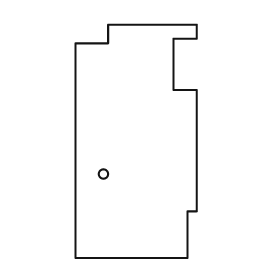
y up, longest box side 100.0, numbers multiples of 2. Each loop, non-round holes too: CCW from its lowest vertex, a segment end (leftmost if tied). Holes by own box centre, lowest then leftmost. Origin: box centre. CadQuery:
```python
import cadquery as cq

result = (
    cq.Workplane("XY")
    .moveTo(-26.0, -50.0)
    .lineTo(22.0, -50.0)
    .lineTo(22.0, -30.0)
    .lineTo(26.0, -30.0)
    .lineTo(26.0, 22.0)
    .lineTo(16.0, 22.0)
    .lineTo(16.0, 44.0)
    .lineTo(26.0, 44.0)
    .lineTo(26.0, 50.0)
    .lineTo(-12.0, 50.0)
    .lineTo(-12.0, 42.0)
    .lineTo(-26.0, 42.0)
    .close()
    .moveTo(-14.0, -14.0)
    .circle(2.0)
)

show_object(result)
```